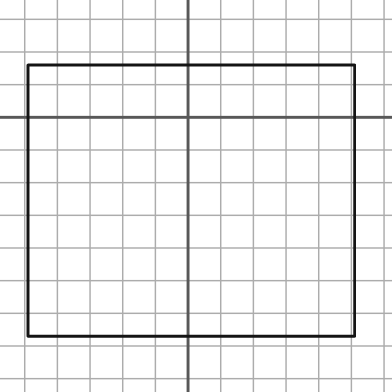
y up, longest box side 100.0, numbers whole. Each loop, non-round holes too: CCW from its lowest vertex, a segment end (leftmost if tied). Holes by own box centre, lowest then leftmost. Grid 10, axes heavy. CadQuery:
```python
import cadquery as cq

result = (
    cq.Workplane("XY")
    .moveTo(-49.0, -67.0)
    .lineTo(51.0, -67.0)
    .lineTo(51.0, 16.0)
    .lineTo(-49.0, 16.0)
    .close()
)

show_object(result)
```